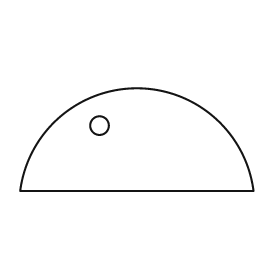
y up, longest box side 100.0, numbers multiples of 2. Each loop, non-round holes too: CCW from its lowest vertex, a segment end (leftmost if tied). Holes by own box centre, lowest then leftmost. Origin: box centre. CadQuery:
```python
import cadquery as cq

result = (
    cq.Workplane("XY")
    .moveTo(-50.0, -22.0)
    .lineTo(50.0, -22.0)
    .threePointArc((0.0, 22.0), (-50.0, -22.0))
    .close()
    .moveTo(-16.0, 6.0)
    .circle(4.0)
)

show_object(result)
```